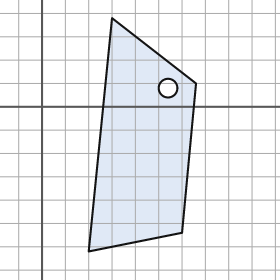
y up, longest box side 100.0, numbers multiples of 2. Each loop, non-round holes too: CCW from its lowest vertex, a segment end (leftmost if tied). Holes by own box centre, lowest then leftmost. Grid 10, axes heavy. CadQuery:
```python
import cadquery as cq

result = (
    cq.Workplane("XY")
    .moveTo(20.0, -62.0)
    .lineTo(60.0, -54.0)
    .lineTo(66.0, 10.0)
    .lineTo(30.0, 38.0)
    .close()
    .moveTo(54.0, 8.0)
    .circle(4.0)
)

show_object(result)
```